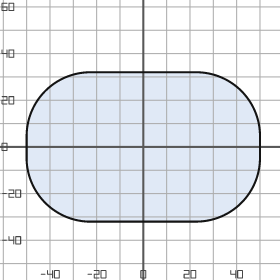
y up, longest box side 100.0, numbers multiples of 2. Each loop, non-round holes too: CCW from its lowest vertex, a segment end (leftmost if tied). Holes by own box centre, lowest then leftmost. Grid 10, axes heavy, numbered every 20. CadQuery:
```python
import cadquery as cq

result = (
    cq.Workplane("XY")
    .moveTo(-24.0, -32.0)
    .lineTo(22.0, -32.0)
    .threePointArc((42.0, -24.0), (50.0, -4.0))
    .lineTo(50.0, 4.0)
    .threePointArc((42.0, 24.0), (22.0, 32.0))
    .lineTo(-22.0, 32.0)
    .threePointArc((-42.0, 24.0), (-50.0, 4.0))
    .lineTo(-50.0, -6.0)
    .threePointArc((-42.0, -24.0), (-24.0, -32.0))
    .close()
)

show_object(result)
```